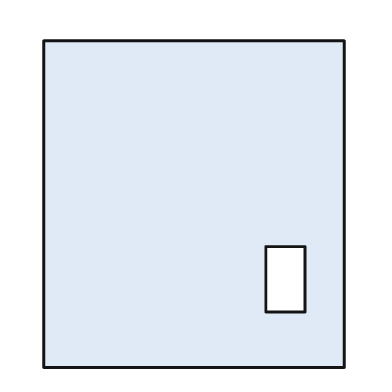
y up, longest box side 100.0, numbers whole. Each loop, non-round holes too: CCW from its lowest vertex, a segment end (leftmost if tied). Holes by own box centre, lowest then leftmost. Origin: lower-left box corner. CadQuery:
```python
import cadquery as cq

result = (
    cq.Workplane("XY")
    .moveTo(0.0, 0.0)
    .lineTo(92.0, 0.0)
    .lineTo(92.0, 100.0)
    .lineTo(0.0, 100.0)
    .close()
    .moveTo(68.0, 17.0)
    .lineTo(80.0, 17.0)
    .lineTo(80.0, 37.0)
    .lineTo(68.0, 37.0)
    .close()
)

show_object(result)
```